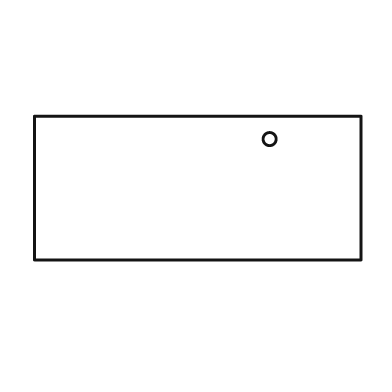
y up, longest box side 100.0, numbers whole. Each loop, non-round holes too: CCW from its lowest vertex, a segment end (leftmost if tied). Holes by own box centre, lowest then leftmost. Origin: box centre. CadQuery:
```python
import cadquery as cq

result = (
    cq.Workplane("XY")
    .moveTo(-50.0, -22.0)
    .lineTo(50.0, -22.0)
    .lineTo(50.0, 22.0)
    .lineTo(-50.0, 22.0)
    .close()
    .moveTo(22.0, 15.0)
    .circle(2.0)
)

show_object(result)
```